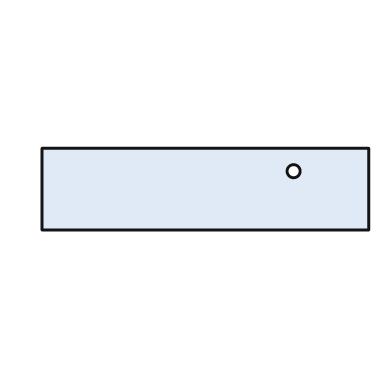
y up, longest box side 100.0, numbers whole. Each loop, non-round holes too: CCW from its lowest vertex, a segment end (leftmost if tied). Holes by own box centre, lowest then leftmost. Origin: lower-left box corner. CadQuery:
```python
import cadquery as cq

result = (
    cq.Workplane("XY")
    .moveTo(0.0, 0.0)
    .lineTo(100.0, 0.0)
    .lineTo(100.0, 25.0)
    .lineTo(0.0, 25.0)
    .close()
    .moveTo(77.0, 18.0)
    .circle(2.0)
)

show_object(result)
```